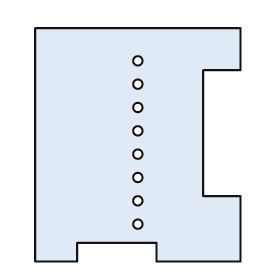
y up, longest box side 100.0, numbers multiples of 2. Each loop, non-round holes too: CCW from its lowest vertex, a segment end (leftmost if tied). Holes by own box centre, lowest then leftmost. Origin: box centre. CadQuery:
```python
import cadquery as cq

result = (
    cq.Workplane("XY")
    .moveTo(-44.0, -50.0)
    .lineTo(-26.0, -50.0)
    .lineTo(-26.0, -42.0)
    .lineTo(8.0, -42.0)
    .lineTo(8.0, -50.0)
    .lineTo(44.0, -50.0)
    .lineTo(44.0, -22.0)
    .lineTo(28.0, -22.0)
    .lineTo(28.0, 32.0)
    .lineTo(44.0, 32.0)
    .lineTo(44.0, 50.0)
    .lineTo(-44.0, 50.0)
    .close()
    .moveTo(0.0, -34.0)
    .circle(2.0)
    .moveTo(0.0, -24.0)
    .circle(2.0)
    .moveTo(0.0, -14.0)
    .circle(2.0)
    .moveTo(0.0, -4.0)
    .circle(2.0)
    .moveTo(0.0, 6.0)
    .circle(2.0)
    .moveTo(0.0, 16.0)
    .circle(2.0)
    .moveTo(0.0, 26.0)
    .circle(2.0)
    .moveTo(0.0, 36.0)
    .circle(2.0)
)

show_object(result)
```